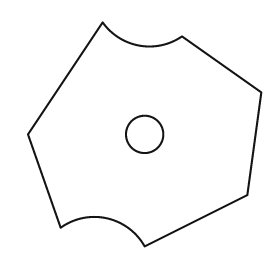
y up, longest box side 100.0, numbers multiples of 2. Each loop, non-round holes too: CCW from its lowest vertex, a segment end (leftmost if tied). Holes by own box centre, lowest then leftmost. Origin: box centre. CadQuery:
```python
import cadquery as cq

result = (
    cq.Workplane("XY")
    .moveTo(0.0, -48.0)
    .lineTo(44.0, -26.0)
    .lineTo(50.0, 18.0)
    .lineTo(16.0, 42.0)
    .threePointArc((-2.0, 38.0), (-18.0, 48.0))
    .lineTo(-50.0, 0.0)
    .lineTo(-36.0, -40.0)
    .threePointArc((-16.0, -36.0), (0.0, -48.0))
    .close()
    .moveTo(0.0, 0.0)
    .circle(8.0)
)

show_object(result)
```